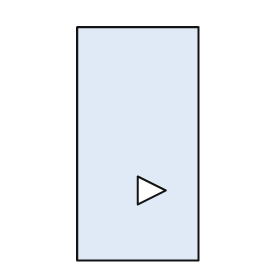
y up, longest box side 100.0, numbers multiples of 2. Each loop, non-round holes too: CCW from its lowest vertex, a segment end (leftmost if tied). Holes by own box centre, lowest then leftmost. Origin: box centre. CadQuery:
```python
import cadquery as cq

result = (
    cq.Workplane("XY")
    .moveTo(-26.0, -50.0)
    .lineTo(26.0, -50.0)
    .lineTo(26.0, 50.0)
    .lineTo(-26.0, 50.0)
    .close()
    .moveTo(0.0, -26.0)
    .lineTo(12.0, -20.0)
    .lineTo(0.0, -14.0)
    .close()
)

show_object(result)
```